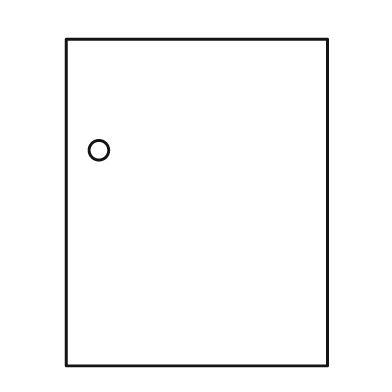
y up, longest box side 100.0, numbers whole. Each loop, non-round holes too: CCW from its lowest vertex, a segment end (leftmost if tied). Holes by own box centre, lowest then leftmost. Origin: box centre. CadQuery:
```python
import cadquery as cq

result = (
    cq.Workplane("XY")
    .moveTo(-40.0, -50.0)
    .lineTo(40.0, -50.0)
    .lineTo(40.0, 50.0)
    .lineTo(-40.0, 50.0)
    .close()
    .moveTo(-30.0, 16.0)
    .circle(3.0)
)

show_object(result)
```